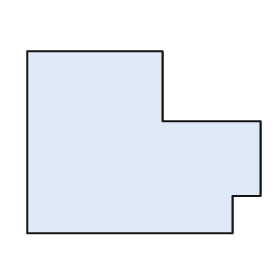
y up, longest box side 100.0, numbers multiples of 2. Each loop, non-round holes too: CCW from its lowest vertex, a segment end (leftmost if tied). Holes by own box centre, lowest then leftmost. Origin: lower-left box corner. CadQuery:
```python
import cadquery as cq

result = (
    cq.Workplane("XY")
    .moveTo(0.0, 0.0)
    .lineTo(88.0, 0.0)
    .lineTo(88.0, 16.0)
    .lineTo(100.0, 16.0)
    .lineTo(100.0, 48.0)
    .lineTo(58.0, 48.0)
    .lineTo(58.0, 78.0)
    .lineTo(0.0, 78.0)
    .close()
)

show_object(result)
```